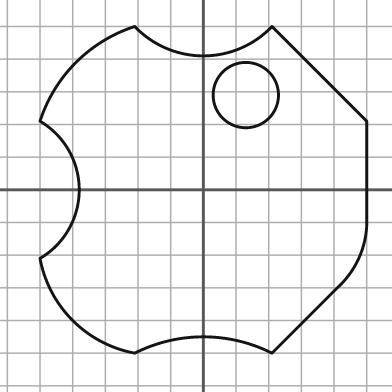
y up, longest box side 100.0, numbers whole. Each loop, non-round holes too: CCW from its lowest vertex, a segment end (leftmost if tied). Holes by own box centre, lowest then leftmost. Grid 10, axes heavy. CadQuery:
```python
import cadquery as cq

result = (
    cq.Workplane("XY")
    .moveTo(-21.0, -50.0)
    .threePointArc((0.0, -45.0), (21.0, -50.0))
    .lineTo(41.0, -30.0)
    .threePointArc((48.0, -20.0), (50.0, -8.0))
    .lineTo(50.0, 21.0)
    .lineTo(21.0, 50.0)
    .threePointArc((0.0, 41.0), (-21.0, 50.0))
    .threePointArc((-39.0, 39.0), (-50.0, 21.0))
    .threePointArc((-38.0, 0.0), (-50.0, -21.0))
    .threePointArc((-40.0, -40.0), (-21.0, -50.0))
    .close()
    .moveTo(13.0, 29.0)
    .circle(10.0)
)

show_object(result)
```